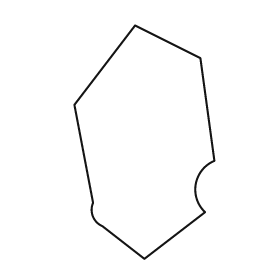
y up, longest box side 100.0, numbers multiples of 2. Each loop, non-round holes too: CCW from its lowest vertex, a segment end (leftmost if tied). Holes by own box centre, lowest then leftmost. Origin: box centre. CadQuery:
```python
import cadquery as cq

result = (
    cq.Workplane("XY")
    .moveTo(0.0, -50.0)
    .lineTo(26.0, -30.0)
    .threePointArc((22.0, -18.0), (30.0, -8.0))
    .lineTo(24.0, 36.0)
    .lineTo(-4.0, 50.0)
    .lineTo(-30.0, 16.0)
    .lineTo(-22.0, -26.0)
    .threePointArc((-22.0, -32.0), (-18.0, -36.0))
    .close()
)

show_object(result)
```